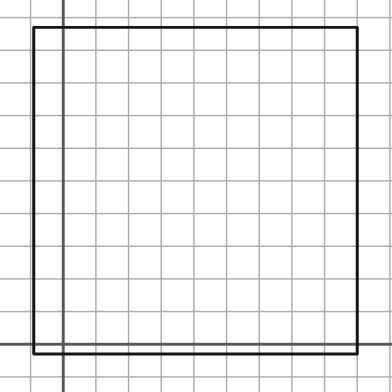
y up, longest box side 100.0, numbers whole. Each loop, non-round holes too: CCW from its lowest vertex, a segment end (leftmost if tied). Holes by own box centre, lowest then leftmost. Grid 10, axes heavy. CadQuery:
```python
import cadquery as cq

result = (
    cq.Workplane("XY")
    .moveTo(-9.0, -3.0)
    .lineTo(90.0, -3.0)
    .lineTo(90.0, 97.0)
    .lineTo(-9.0, 97.0)
    .close()
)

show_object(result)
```